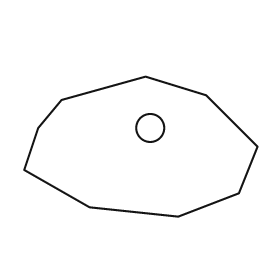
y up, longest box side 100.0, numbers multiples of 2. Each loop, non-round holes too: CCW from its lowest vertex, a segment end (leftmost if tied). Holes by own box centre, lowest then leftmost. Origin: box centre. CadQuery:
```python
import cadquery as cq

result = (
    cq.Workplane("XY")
    .moveTo(16.0, -30.0)
    .lineTo(42.0, -20.0)
    .lineTo(50.0, 0.0)
    .lineTo(28.0, 22.0)
    .lineTo(2.0, 30.0)
    .lineTo(-34.0, 20.0)
    .lineTo(-44.0, 8.0)
    .lineTo(-50.0, -10.0)
    .lineTo(-22.0, -26.0)
    .close()
    .moveTo(4.0, 8.0)
    .circle(6.0)
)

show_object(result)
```